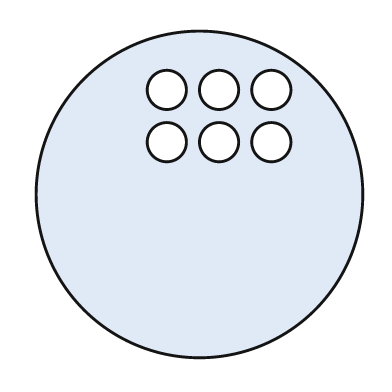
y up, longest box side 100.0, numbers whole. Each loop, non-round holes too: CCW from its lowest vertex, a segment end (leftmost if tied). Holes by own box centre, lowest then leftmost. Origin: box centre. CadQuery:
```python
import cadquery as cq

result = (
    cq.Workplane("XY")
    .moveTo(0.0, 0.0)
    .circle(50.0)
    .moveTo(-10.0, 16.0)
    .circle(6.0)
    .moveTo(6.0, 16.0)
    .circle(6.0)
    .moveTo(22.0, 16.0)
    .circle(6.0)
    .moveTo(-10.0, 32.0)
    .circle(6.0)
    .moveTo(6.0, 32.0)
    .circle(6.0)
    .moveTo(22.0, 32.0)
    .circle(6.0)
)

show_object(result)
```